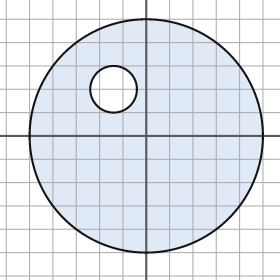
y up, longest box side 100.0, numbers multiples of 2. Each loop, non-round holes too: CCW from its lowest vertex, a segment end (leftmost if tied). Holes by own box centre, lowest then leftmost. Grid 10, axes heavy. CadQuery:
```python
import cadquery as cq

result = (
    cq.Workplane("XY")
    .moveTo(0.0, 0.0)
    .circle(50.0)
    .moveTo(-14.0, 20.0)
    .circle(10.0)
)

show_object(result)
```